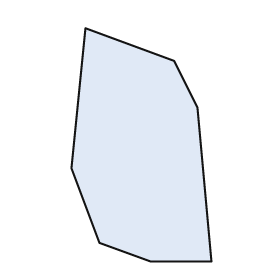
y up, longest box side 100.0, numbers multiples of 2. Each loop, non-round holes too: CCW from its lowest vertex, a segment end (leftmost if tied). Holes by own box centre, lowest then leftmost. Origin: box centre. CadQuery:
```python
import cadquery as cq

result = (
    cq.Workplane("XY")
    .moveTo(4.0, -50.0)
    .lineTo(30.0, -50.0)
    .lineTo(24.0, 16.0)
    .lineTo(14.0, 36.0)
    .lineTo(-24.0, 50.0)
    .lineTo(-30.0, -10.0)
    .lineTo(-18.0, -42.0)
    .close()
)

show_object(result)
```